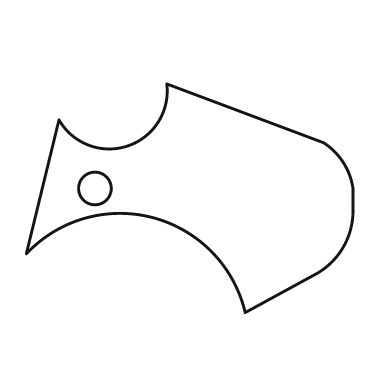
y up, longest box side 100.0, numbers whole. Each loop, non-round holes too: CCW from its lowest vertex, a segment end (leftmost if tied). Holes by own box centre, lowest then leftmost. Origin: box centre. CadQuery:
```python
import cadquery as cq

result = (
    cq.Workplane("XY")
    .moveTo(17.0, -35.0)
    .lineTo(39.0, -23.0)
    .threePointArc((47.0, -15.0), (50.0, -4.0))
    .lineTo(50.0, 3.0)
    .threePointArc((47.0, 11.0), (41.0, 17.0))
    .lineTo(-7.0, 35.0)
    .threePointArc((-19.0, 16.0), (-40.0, 24.0))
    .lineTo(-50.0, -17.0)
    .threePointArc((-11.0, -6.0), (17.0, -35.0))
    .close()
    .moveTo(-29.0, 3.0)
    .circle(5.0)
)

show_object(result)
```